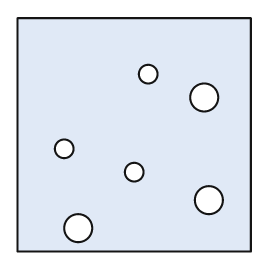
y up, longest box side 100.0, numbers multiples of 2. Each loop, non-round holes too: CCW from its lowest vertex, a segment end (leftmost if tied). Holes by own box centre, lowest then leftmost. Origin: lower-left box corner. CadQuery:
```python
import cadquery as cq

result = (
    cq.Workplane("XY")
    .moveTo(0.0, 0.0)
    .lineTo(100.0, 0.0)
    .lineTo(100.0, 100.0)
    .lineTo(0.0, 100.0)
    .close()
    .moveTo(26.0, 10.0)
    .circle(6.0)
    .moveTo(82.0, 22.0)
    .circle(6.0)
    .moveTo(50.0, 34.0)
    .circle(4.0)
    .moveTo(20.0, 44.0)
    .circle(4.0)
    .moveTo(80.0, 66.0)
    .circle(6.0)
    .moveTo(56.0, 76.0)
    .circle(4.0)
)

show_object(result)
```